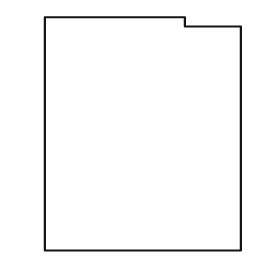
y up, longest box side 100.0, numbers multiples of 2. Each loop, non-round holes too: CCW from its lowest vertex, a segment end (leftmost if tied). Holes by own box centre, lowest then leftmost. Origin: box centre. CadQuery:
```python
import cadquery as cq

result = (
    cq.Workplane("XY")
    .moveTo(-42.0, -50.0)
    .lineTo(42.0, -50.0)
    .lineTo(42.0, 46.0)
    .lineTo(18.0, 46.0)
    .lineTo(18.0, 50.0)
    .lineTo(-42.0, 50.0)
    .close()
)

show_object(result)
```